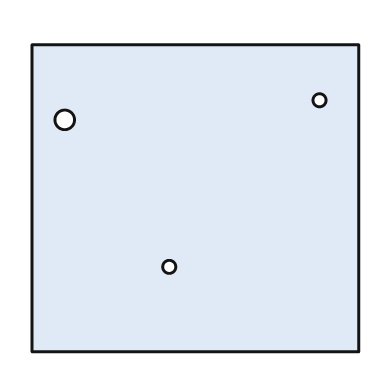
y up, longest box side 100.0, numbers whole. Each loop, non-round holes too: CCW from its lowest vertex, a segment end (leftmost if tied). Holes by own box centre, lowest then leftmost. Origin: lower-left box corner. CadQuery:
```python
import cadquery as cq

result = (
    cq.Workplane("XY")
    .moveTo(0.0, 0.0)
    .lineTo(100.0, 0.0)
    .lineTo(100.0, 94.0)
    .lineTo(0.0, 94.0)
    .close()
    .moveTo(42.0, 26.0)
    .circle(2.0)
    .moveTo(10.0, 71.0)
    .circle(3.0)
    .moveTo(88.0, 77.0)
    .circle(2.0)
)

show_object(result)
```